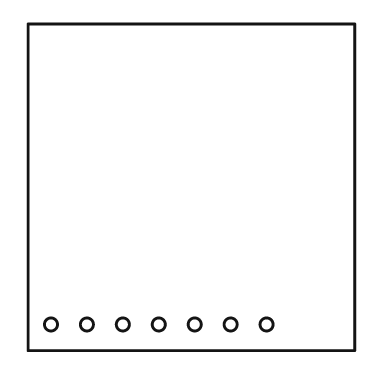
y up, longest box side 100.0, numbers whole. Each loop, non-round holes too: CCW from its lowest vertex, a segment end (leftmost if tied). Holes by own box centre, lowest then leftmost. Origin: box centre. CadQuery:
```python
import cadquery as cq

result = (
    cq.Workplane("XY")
    .moveTo(-50.0, -50.0)
    .lineTo(50.0, -50.0)
    .lineTo(50.0, 50.0)
    .lineTo(-50.0, 50.0)
    .close()
    .moveTo(-43.0, -42.0)
    .circle(2.0)
    .moveTo(-32.0, -42.0)
    .circle(2.0)
    .moveTo(-21.0, -42.0)
    .circle(2.0)
    .moveTo(-10.0, -42.0)
    .circle(2.0)
    .moveTo(1.0, -42.0)
    .circle(2.0)
    .moveTo(12.0, -42.0)
    .circle(2.0)
    .moveTo(23.0, -42.0)
    .circle(2.0)
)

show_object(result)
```